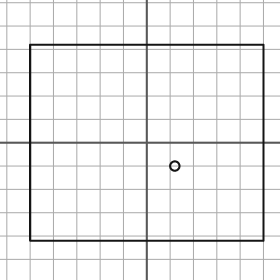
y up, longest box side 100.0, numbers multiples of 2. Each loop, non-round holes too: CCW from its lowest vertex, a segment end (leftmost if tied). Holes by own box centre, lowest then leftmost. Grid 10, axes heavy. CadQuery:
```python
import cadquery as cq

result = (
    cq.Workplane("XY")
    .moveTo(-50.0, -42.0)
    .lineTo(50.0, -42.0)
    .lineTo(50.0, 42.0)
    .lineTo(-50.0, 42.0)
    .close()
    .moveTo(12.0, -10.0)
    .circle(2.0)
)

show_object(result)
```